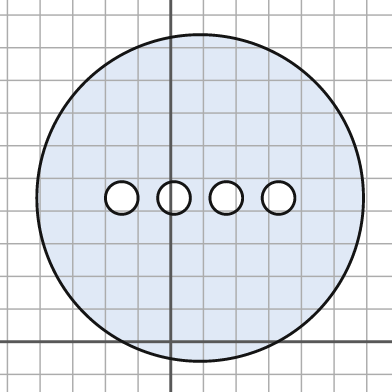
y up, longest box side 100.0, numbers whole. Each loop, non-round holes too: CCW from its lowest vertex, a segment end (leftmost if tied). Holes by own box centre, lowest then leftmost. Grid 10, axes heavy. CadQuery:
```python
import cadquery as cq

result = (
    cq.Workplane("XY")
    .moveTo(9.0, 44.0)
    .circle(50.0)
    .moveTo(-15.0, 44.0)
    .circle(5.0)
    .moveTo(1.0, 44.0)
    .circle(5.0)
    .moveTo(17.0, 44.0)
    .circle(5.0)
    .moveTo(33.0, 44.0)
    .circle(5.0)
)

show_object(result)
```